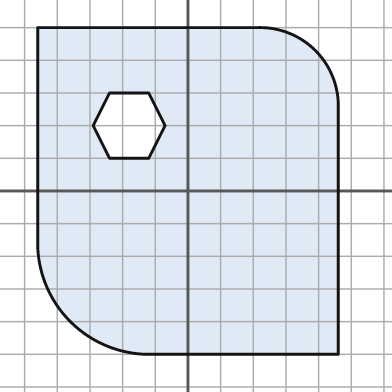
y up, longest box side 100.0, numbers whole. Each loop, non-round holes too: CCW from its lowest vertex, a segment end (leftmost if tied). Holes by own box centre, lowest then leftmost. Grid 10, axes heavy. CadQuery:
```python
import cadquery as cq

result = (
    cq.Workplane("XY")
    .moveTo(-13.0, -50.0)
    .lineTo(46.0, -50.0)
    .lineTo(46.0, 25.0)
    .threePointArc((39.0, 43.0), (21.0, 50.0))
    .lineTo(-46.0, 50.0)
    .lineTo(-46.0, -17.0)
    .threePointArc((-36.0, -40.0), (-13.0, -50.0))
    .close()
    .moveTo(-24.0, 10.0)
    .lineTo(-12.0, 10.0)
    .lineTo(-7.0, 20.0)
    .lineTo(-12.0, 30.0)
    .lineTo(-24.0, 30.0)
    .lineTo(-29.0, 20.0)
    .close()
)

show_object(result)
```